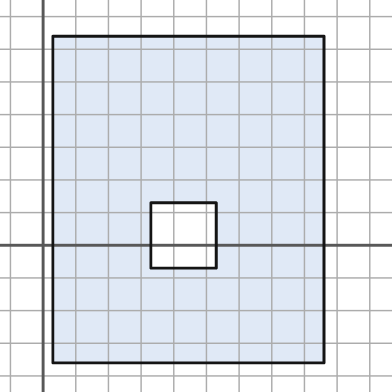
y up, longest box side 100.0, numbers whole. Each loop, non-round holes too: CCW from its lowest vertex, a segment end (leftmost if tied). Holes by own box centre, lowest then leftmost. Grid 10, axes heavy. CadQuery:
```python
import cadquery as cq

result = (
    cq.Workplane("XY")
    .moveTo(3.0, -36.0)
    .lineTo(86.0, -36.0)
    .lineTo(86.0, 64.0)
    .lineTo(3.0, 64.0)
    .close()
    .moveTo(33.0, -7.0)
    .lineTo(53.0, -7.0)
    .lineTo(53.0, 13.0)
    .lineTo(33.0, 13.0)
    .close()
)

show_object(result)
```